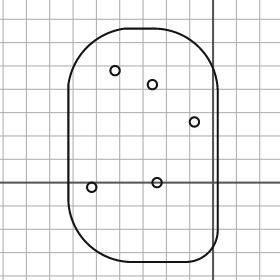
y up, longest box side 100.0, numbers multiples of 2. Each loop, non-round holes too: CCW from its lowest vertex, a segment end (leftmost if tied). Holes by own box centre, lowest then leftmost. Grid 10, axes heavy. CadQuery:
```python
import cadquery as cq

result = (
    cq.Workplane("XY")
    .moveTo(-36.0, -34.0)
    .lineTo(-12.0, -34.0)
    .threePointArc((-2.0, -30.0), (2.0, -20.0))
    .lineTo(2.0, 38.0)
    .threePointArc((-6.0, 58.0), (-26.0, 66.0))
    .lineTo(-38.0, 66.0)
    .threePointArc((-54.0, 58.0), (-62.0, 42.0))
    .lineTo(-62.0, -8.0)
    .threePointArc((-54.0, -26.0), (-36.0, -34.0))
    .close()
    .moveTo(-52.0, -2.0)
    .circle(2.0)
    .moveTo(-24.0, 0.0)
    .circle(2.0)
    .moveTo(-8.0, 26.0)
    .circle(2.0)
    .moveTo(-26.0, 42.0)
    .circle(2.0)
    .moveTo(-42.0, 48.0)
    .circle(2.0)
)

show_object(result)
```